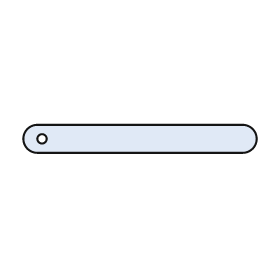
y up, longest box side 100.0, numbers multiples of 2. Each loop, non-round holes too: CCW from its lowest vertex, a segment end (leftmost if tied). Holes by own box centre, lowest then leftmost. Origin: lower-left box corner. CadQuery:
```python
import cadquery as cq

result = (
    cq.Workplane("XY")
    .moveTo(6.0, 0.0)
    .lineTo(94.0, 0.0)
    .threePointArc((100.0, 6.0), (94.0, 12.0))
    .lineTo(6.0, 12.0)
    .threePointArc((0.0, 6.0), (6.0, 0.0))
    .close()
    .moveTo(8.0, 6.0)
    .circle(2.0)
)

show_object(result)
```